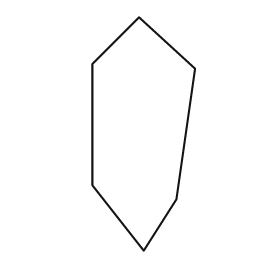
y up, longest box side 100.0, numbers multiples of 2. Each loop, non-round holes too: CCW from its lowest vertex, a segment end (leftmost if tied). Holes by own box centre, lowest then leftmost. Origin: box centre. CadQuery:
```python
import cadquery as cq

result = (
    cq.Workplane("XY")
    .moveTo(0.0, -50.0)
    .lineTo(14.0, -28.0)
    .lineTo(22.0, 28.0)
    .lineTo(-2.0, 50.0)
    .lineTo(-22.0, 30.0)
    .lineTo(-22.0, -22.0)
    .close()
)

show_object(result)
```